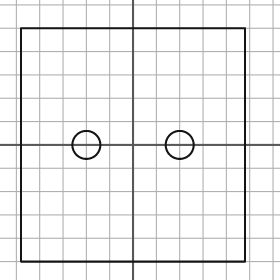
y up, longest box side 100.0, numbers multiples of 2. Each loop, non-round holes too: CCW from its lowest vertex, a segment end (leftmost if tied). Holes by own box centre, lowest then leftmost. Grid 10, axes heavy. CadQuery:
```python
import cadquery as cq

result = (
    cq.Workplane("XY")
    .moveTo(-48.0, -50.0)
    .lineTo(48.0, -50.0)
    .lineTo(48.0, 50.0)
    .lineTo(-48.0, 50.0)
    .close()
    .moveTo(-20.0, 0.0)
    .circle(6.0)
    .moveTo(20.0, 0.0)
    .circle(6.0)
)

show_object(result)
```